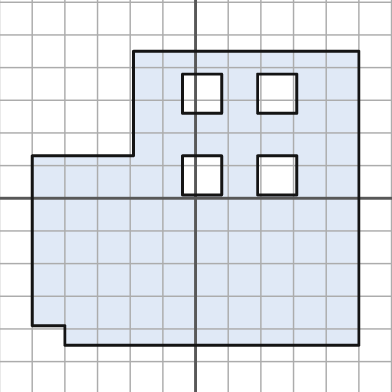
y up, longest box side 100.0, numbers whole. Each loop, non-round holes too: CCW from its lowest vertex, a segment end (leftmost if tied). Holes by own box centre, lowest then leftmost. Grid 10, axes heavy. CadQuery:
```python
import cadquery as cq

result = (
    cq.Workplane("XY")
    .moveTo(-40.0, -45.0)
    .lineTo(50.0, -45.0)
    .lineTo(50.0, 45.0)
    .lineTo(-19.0, 45.0)
    .lineTo(-19.0, 13.0)
    .lineTo(-50.0, 13.0)
    .lineTo(-50.0, -39.0)
    .lineTo(-40.0, -39.0)
    .close()
    .moveTo(-4.0, 1.0)
    .lineTo(8.0, 1.0)
    .lineTo(8.0, 13.0)
    .lineTo(-4.0, 13.0)
    .close()
    .moveTo(19.0, 1.0)
    .lineTo(31.0, 1.0)
    .lineTo(31.0, 13.0)
    .lineTo(19.0, 13.0)
    .close()
    .moveTo(-4.0, 26.0)
    .lineTo(8.0, 26.0)
    .lineTo(8.0, 38.0)
    .lineTo(-4.0, 38.0)
    .close()
    .moveTo(19.0, 26.0)
    .lineTo(31.0, 26.0)
    .lineTo(31.0, 38.0)
    .lineTo(19.0, 38.0)
    .close()
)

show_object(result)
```